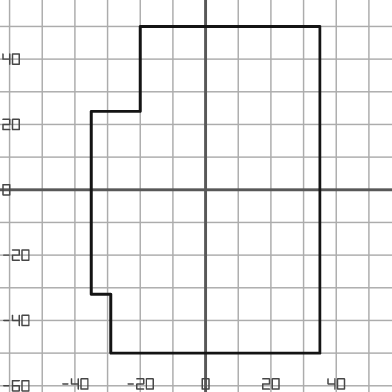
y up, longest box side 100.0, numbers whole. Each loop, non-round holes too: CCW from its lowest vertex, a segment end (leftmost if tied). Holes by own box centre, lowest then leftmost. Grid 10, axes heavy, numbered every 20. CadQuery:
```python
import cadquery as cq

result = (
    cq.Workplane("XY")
    .moveTo(-29.0, -50.0)
    .lineTo(35.0, -50.0)
    .lineTo(35.0, 50.0)
    .lineTo(-20.0, 50.0)
    .lineTo(-20.0, 24.0)
    .lineTo(-35.0, 24.0)
    .lineTo(-35.0, -32.0)
    .lineTo(-29.0, -32.0)
    .close()
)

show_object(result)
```